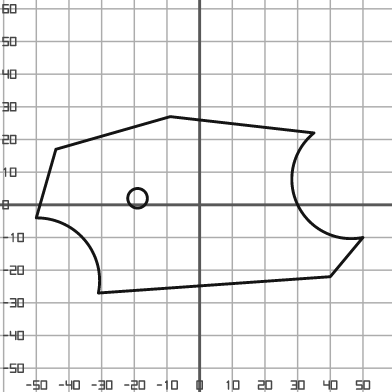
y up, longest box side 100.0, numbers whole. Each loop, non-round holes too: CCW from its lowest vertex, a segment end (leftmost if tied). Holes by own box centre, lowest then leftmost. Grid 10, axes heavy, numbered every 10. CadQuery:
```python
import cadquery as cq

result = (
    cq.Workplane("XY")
    .moveTo(-31.0, -27.0)
    .lineTo(40.0, -22.0)
    .lineTo(50.0, -10.0)
    .threePointArc((30.0, 0.0), (35.0, 22.0))
    .lineTo(-9.0, 27.0)
    .lineTo(-44.0, 17.0)
    .lineTo(-50.0, -4.0)
    .threePointArc((-35.0, -11.0), (-31.0, -27.0))
    .close()
    .moveTo(-19.0, 2.0)
    .circle(3.0)
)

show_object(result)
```